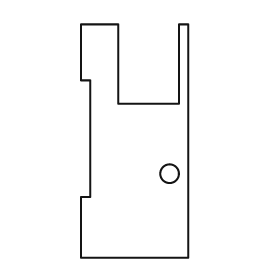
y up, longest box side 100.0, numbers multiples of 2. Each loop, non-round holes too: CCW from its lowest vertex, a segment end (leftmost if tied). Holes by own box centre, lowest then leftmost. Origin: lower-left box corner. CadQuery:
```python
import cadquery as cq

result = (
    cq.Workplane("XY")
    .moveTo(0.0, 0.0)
    .lineTo(46.0, 0.0)
    .lineTo(46.0, 100.0)
    .lineTo(42.0, 100.0)
    .lineTo(42.0, 66.0)
    .lineTo(16.0, 66.0)
    .lineTo(16.0, 100.0)
    .lineTo(0.0, 100.0)
    .lineTo(0.0, 76.0)
    .lineTo(4.0, 76.0)
    .lineTo(4.0, 26.0)
    .lineTo(0.0, 26.0)
    .close()
    .moveTo(38.0, 36.0)
    .circle(4.0)
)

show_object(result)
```